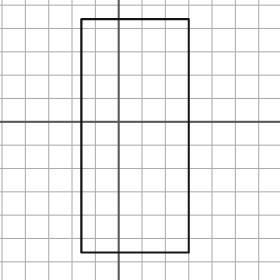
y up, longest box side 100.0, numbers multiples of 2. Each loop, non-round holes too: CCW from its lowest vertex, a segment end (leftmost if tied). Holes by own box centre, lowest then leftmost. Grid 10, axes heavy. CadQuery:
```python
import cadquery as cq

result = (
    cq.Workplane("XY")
    .moveTo(-16.0, -56.0)
    .lineTo(30.0, -56.0)
    .lineTo(30.0, 44.0)
    .lineTo(-16.0, 44.0)
    .close()
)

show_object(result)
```